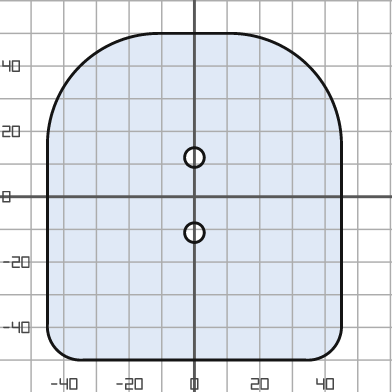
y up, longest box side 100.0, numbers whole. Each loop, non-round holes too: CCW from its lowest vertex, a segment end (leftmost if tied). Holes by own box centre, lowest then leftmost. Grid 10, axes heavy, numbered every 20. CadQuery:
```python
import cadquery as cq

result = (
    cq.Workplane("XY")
    .moveTo(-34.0, -50.0)
    .lineTo(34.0, -50.0)
    .threePointArc((42.0, -47.0), (45.0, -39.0))
    .lineTo(45.0, 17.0)
    .threePointArc((35.0, 40.0), (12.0, 50.0))
    .lineTo(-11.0, 50.0)
    .threePointArc((-35.0, 40.0), (-45.0, 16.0))
    .lineTo(-45.0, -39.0)
    .threePointArc((-42.0, -47.0), (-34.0, -50.0))
    .close()
    .moveTo(0.0, -11.0)
    .circle(3.0)
    .moveTo(0.0, 12.0)
    .circle(3.0)
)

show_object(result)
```